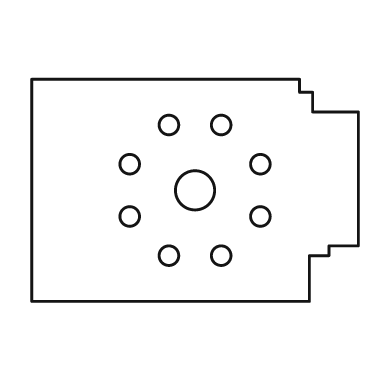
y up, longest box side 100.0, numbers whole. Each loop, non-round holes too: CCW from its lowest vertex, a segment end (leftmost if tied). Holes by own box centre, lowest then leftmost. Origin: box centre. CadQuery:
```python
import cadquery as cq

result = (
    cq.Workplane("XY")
    .moveTo(-50.0, -34.0)
    .lineTo(35.0, -34.0)
    .lineTo(35.0, -20.0)
    .lineTo(41.0, -20.0)
    .lineTo(41.0, -17.0)
    .lineTo(50.0, -17.0)
    .lineTo(50.0, 24.0)
    .lineTo(36.0, 24.0)
    .lineTo(36.0, 30.0)
    .lineTo(32.0, 30.0)
    .lineTo(32.0, 34.0)
    .lineTo(-50.0, 34.0)
    .close()
    .moveTo(-8.0, -20.0)
    .circle(3.0)
    .moveTo(8.0, -20.0)
    .circle(3.0)
    .moveTo(-20.0, -8.0)
    .circle(3.0)
    .moveTo(20.0, -8.0)
    .circle(3.0)
    .moveTo(0.0, 0.0)
    .circle(6.0)
    .moveTo(-20.0, 8.0)
    .circle(3.0)
    .moveTo(20.0, 8.0)
    .circle(3.0)
    .moveTo(-8.0, 20.0)
    .circle(3.0)
    .moveTo(8.0, 20.0)
    .circle(3.0)
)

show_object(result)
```